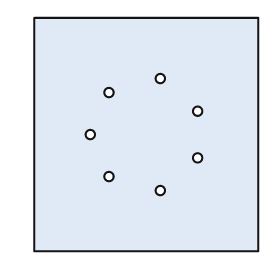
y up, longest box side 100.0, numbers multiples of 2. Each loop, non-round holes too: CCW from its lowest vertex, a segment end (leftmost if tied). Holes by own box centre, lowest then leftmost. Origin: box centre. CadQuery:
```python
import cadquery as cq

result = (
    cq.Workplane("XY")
    .moveTo(-48.0, -50.0)
    .lineTo(48.0, -50.0)
    .lineTo(48.0, 50.0)
    .lineTo(-48.0, 50.0)
    .close()
    .moveTo(6.0, -24.0)
    .circle(2.0)
    .moveTo(-16.0, -18.0)
    .circle(2.0)
    .moveTo(22.0, -10.0)
    .circle(2.0)
    .moveTo(-24.0, 0.0)
    .circle(2.0)
    .moveTo(22.0, 10.0)
    .circle(2.0)
    .moveTo(-16.0, 18.0)
    .circle(2.0)
    .moveTo(6.0, 24.0)
    .circle(2.0)
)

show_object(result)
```